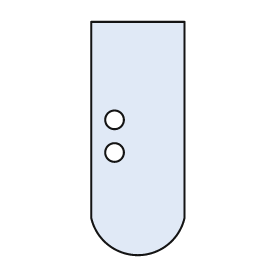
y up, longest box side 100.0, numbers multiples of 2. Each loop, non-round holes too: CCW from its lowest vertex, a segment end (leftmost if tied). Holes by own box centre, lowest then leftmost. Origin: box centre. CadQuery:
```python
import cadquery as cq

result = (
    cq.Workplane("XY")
    .moveTo(-20.0, -34.0)
    .threePointArc((0.0, -50.0), (20.0, -34.0))
    .lineTo(20.0, 50.0)
    .lineTo(-20.0, 50.0)
    .close()
    .moveTo(-10.0, -6.0)
    .circle(4.0)
    .moveTo(-10.0, 8.0)
    .circle(4.0)
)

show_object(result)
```